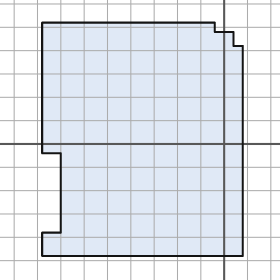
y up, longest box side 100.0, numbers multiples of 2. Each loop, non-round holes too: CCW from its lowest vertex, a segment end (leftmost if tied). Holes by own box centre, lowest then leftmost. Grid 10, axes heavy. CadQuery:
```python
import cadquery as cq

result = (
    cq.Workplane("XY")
    .moveTo(-78.0, -48.0)
    .lineTo(8.0, -48.0)
    .lineTo(8.0, 42.0)
    .lineTo(4.0, 42.0)
    .lineTo(4.0, 48.0)
    .lineTo(-4.0, 48.0)
    .lineTo(-4.0, 52.0)
    .lineTo(-78.0, 52.0)
    .lineTo(-78.0, -4.0)
    .lineTo(-70.0, -4.0)
    .lineTo(-70.0, -38.0)
    .lineTo(-78.0, -38.0)
    .close()
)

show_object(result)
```